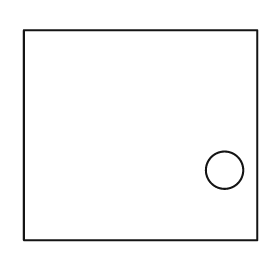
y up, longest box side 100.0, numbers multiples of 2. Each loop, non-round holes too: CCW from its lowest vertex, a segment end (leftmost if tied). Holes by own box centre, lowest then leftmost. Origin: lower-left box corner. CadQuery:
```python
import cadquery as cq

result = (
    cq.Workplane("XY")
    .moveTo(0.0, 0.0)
    .lineTo(100.0, 0.0)
    .lineTo(100.0, 90.0)
    .lineTo(0.0, 90.0)
    .close()
    .moveTo(86.0, 30.0)
    .circle(8.0)
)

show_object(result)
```